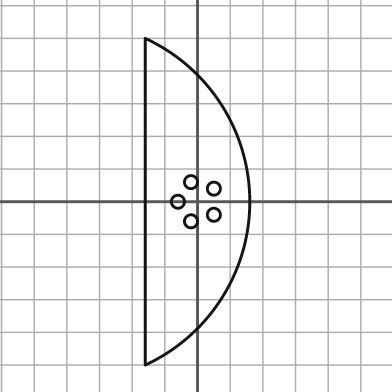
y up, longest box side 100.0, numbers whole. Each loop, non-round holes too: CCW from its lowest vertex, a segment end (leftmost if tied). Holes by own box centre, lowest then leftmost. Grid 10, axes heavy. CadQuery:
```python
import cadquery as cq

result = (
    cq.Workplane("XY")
    .moveTo(-16.0, -50.0)
    .threePointArc((16.0, 0.0), (-16.0, 50.0))
    .close()
    .moveTo(-2.0, -6.0)
    .circle(2.0)
    .moveTo(5.0, -4.0)
    .circle(2.0)
    .moveTo(-6.0, 0.0)
    .circle(2.0)
    .moveTo(5.0, 4.0)
    .circle(2.0)
    .moveTo(-2.0, 6.0)
    .circle(2.0)
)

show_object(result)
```